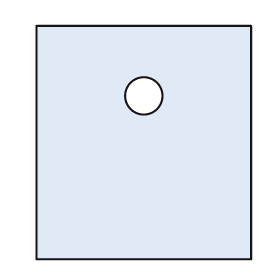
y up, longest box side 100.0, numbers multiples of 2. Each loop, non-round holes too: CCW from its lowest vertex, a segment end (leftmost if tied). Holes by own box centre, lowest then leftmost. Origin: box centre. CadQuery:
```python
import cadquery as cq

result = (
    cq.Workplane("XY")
    .moveTo(-46.0, -50.0)
    .lineTo(46.0, -50.0)
    .lineTo(46.0, 50.0)
    .lineTo(-46.0, 50.0)
    .close()
    .moveTo(0.0, 20.0)
    .circle(8.0)
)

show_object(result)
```